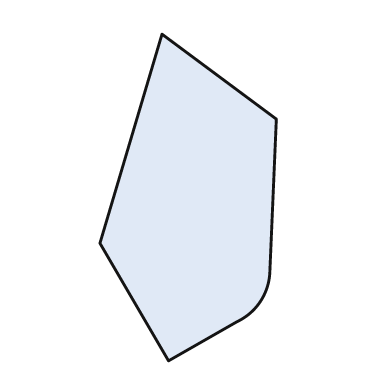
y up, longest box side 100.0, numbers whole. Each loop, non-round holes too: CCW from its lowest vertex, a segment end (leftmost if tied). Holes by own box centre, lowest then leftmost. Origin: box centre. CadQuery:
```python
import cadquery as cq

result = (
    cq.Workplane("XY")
    .moveTo(-6.0, -50.0)
    .lineTo(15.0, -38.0)
    .threePointArc((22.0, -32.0), (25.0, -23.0))
    .lineTo(27.0, 24.0)
    .lineTo(-8.0, 50.0)
    .lineTo(-27.0, -14.0)
    .close()
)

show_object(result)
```